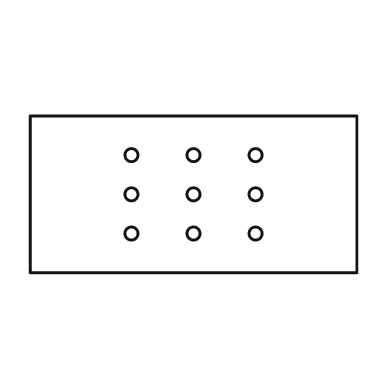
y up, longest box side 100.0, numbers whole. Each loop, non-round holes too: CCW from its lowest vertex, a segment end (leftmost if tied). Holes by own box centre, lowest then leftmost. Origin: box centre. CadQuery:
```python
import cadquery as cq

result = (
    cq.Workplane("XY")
    .moveTo(-50.0, -24.0)
    .lineTo(50.0, -24.0)
    .lineTo(50.0, 24.0)
    .lineTo(-50.0, 24.0)
    .close()
    .moveTo(-19.0, -12.0)
    .circle(2.0)
    .moveTo(0.0, -12.0)
    .circle(2.0)
    .moveTo(19.0, -12.0)
    .circle(2.0)
    .moveTo(-19.0, 0.0)
    .circle(2.0)
    .moveTo(0.0, 0.0)
    .circle(2.0)
    .moveTo(19.0, 0.0)
    .circle(2.0)
    .moveTo(-19.0, 12.0)
    .circle(2.0)
    .moveTo(0.0, 12.0)
    .circle(2.0)
    .moveTo(19.0, 12.0)
    .circle(2.0)
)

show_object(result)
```